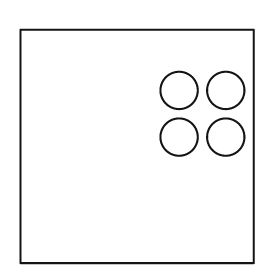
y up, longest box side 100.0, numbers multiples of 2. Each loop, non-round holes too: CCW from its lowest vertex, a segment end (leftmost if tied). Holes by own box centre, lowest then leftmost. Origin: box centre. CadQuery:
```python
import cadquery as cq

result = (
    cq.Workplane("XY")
    .moveTo(-50.0, -50.0)
    .lineTo(50.0, -50.0)
    .lineTo(50.0, 50.0)
    .lineTo(-50.0, 50.0)
    .close()
    .moveTo(18.0, 4.0)
    .circle(8.0)
    .moveTo(38.0, 4.0)
    .circle(8.0)
    .moveTo(18.0, 24.0)
    .circle(8.0)
    .moveTo(38.0, 24.0)
    .circle(8.0)
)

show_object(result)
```